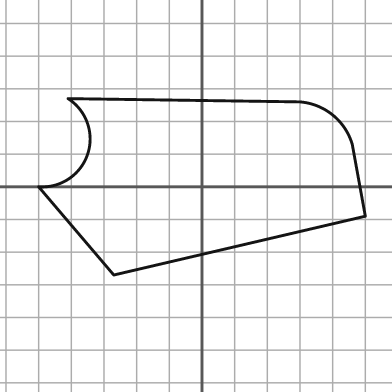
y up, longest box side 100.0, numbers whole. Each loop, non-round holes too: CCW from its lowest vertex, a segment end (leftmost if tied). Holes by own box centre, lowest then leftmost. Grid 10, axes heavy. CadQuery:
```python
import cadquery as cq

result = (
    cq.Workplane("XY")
    .moveTo(-27.0, -27.0)
    .lineTo(50.0, -9.0)
    .lineTo(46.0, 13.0)
    .threePointArc((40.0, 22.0), (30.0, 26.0))
    .lineTo(-41.0, 27.0)
    .threePointArc((-35.0, 10.0), (-50.0, 0.0))
    .close()
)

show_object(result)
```